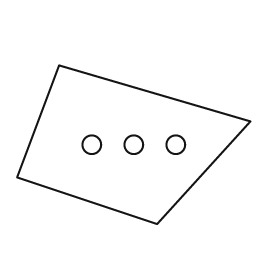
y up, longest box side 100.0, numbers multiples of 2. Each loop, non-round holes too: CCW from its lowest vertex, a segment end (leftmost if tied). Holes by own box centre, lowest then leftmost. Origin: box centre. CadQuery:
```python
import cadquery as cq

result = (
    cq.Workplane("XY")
    .moveTo(10.0, -34.0)
    .lineTo(50.0, 10.0)
    .lineTo(-32.0, 34.0)
    .lineTo(-50.0, -14.0)
    .close()
    .moveTo(-18.0, 0.0)
    .circle(4.0)
    .moveTo(0.0, 0.0)
    .circle(4.0)
    .moveTo(18.0, 0.0)
    .circle(4.0)
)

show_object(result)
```